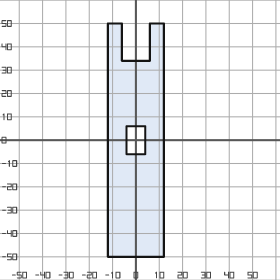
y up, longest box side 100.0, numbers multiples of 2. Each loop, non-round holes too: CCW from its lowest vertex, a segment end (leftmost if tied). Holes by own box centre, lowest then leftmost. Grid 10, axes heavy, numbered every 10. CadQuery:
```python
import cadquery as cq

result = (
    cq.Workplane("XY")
    .moveTo(-12.0, -50.0)
    .lineTo(12.0, -50.0)
    .lineTo(12.0, 50.0)
    .lineTo(6.0, 50.0)
    .lineTo(6.0, 34.0)
    .lineTo(-6.0, 34.0)
    .lineTo(-6.0, 50.0)
    .lineTo(-12.0, 50.0)
    .close()
    .moveTo(-4.0, -6.0)
    .lineTo(4.0, -6.0)
    .lineTo(4.0, 6.0)
    .lineTo(-4.0, 6.0)
    .close()
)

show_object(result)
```